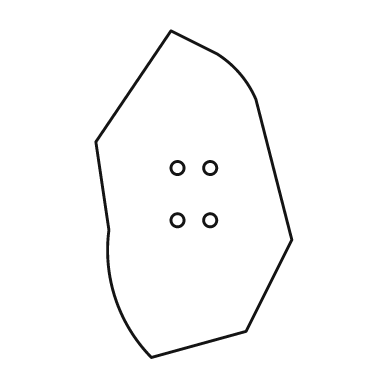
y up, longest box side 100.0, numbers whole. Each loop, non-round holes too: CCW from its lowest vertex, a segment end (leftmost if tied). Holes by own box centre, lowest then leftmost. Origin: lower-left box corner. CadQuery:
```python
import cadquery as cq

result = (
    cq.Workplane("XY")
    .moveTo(17.0, 0.0)
    .lineTo(46.0, 8.0)
    .lineTo(60.0, 36.0)
    .lineTo(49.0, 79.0)
    .threePointArc((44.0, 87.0), (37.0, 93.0))
    .lineTo(23.0, 100.0)
    .lineTo(0.0, 66.0)
    .lineTo(4.0, 39.0)
    .threePointArc((6.0, 18.0), (17.0, 0.0))
    .close()
    .moveTo(25.0, 42.0)
    .circle(2.0)
    .moveTo(35.0, 42.0)
    .circle(2.0)
    .moveTo(25.0, 58.0)
    .circle(2.0)
    .moveTo(35.0, 58.0)
    .circle(2.0)
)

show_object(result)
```